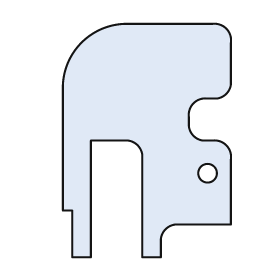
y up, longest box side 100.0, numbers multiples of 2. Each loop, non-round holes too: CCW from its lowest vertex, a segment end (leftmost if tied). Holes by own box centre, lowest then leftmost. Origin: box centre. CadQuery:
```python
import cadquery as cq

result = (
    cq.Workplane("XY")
    .moveTo(-32.0, -50.0)
    .lineTo(-24.0, -50.0)
    .lineTo(-24.0, 0.0)
    .lineTo(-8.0, 0.0)
    .threePointArc((-4.0, -2.0), (-2.0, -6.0))
    .lineTo(-2.0, -50.0)
    .lineTo(6.0, -50.0)
    .lineTo(6.0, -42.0)
    .threePointArc((8.0, -38.0), (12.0, -36.0))
    .lineTo(36.0, -36.0)
    .lineTo(36.0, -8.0)
    .threePointArc((34.0, -2.0), (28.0, 0.0))
    .lineTo(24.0, 0.0)
    .threePointArc((20.0, 2.0), (18.0, 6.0))
    .lineTo(18.0, 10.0)
    .threePointArc((20.0, 16.0), (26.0, 18.0))
    .lineTo(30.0, 18.0)
    .threePointArc((34.0, 20.0), (36.0, 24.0))
    .lineTo(36.0, 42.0)
    .threePointArc((34.0, 48.0), (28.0, 50.0))
    .lineTo(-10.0, 50.0)
    .threePointArc((-28.0, 42.0), (-36.0, 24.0))
    .lineTo(-36.0, -30.0)
    .lineTo(-32.0, -30.0)
    .close()
    .moveTo(26.0, -14.0)
    .circle(4.0)
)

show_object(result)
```